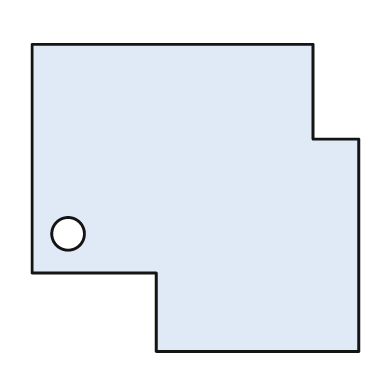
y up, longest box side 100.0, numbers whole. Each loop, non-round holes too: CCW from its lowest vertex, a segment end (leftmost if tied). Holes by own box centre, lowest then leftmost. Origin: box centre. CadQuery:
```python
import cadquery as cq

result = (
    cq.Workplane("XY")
    .moveTo(-12.0, -47.0)
    .lineTo(50.0, -47.0)
    .lineTo(50.0, 18.0)
    .lineTo(36.0, 18.0)
    .lineTo(36.0, 47.0)
    .lineTo(-50.0, 47.0)
    .lineTo(-50.0, -23.0)
    .lineTo(-12.0, -23.0)
    .close()
    .moveTo(-39.0, -11.0)
    .circle(5.0)
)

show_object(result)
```